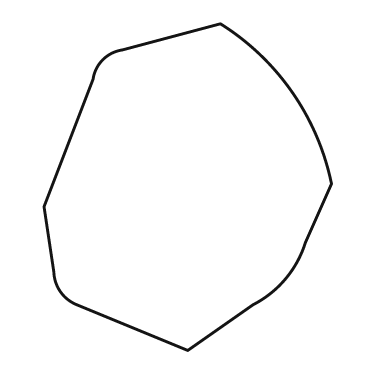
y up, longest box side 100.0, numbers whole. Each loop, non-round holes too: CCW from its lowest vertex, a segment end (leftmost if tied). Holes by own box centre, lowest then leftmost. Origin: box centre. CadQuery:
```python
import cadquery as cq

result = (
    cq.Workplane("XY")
    .moveTo(0.0, -50.0)
    .lineTo(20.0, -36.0)
    .threePointArc((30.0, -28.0), (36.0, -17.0))
    .lineTo(44.0, 1.0)
    .threePointArc((32.0, 29.0), (10.0, 50.0))
    .lineTo(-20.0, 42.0)
    .threePointArc((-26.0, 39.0), (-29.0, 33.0))
    .lineTo(-44.0, -6.0)
    .lineTo(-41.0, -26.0)
    .threePointArc((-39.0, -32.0), (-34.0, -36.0))
    .close()
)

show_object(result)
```